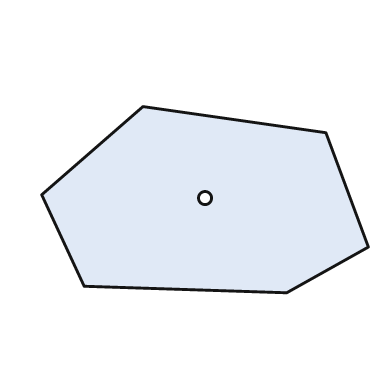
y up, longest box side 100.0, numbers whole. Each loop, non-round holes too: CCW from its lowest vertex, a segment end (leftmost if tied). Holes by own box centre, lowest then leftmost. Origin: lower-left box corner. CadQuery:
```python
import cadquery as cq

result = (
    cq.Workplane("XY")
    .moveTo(75.0, 0.0)
    .lineTo(100.0, 14.0)
    .lineTo(87.0, 49.0)
    .lineTo(31.0, 57.0)
    .lineTo(0.0, 30.0)
    .lineTo(13.0, 2.0)
    .close()
    .moveTo(50.0, 29.0)
    .circle(2.0)
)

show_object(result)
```